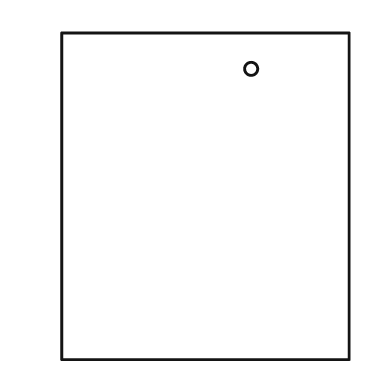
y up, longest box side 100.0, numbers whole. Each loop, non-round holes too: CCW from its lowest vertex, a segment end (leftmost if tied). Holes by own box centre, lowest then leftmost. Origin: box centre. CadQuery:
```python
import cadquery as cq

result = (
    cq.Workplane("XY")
    .moveTo(-44.0, -50.0)
    .lineTo(44.0, -50.0)
    .lineTo(44.0, 50.0)
    .lineTo(-44.0, 50.0)
    .close()
    .moveTo(14.0, 39.0)
    .circle(2.0)
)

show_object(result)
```